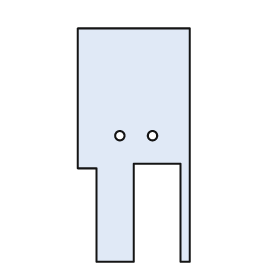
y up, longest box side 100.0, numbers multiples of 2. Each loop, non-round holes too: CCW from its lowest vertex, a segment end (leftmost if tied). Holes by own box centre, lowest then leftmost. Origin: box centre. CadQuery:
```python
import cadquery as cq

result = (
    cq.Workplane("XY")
    .moveTo(-16.0, -50.0)
    .lineTo(0.0, -50.0)
    .lineTo(0.0, -8.0)
    .lineTo(20.0, -8.0)
    .lineTo(20.0, -50.0)
    .lineTo(24.0, -50.0)
    .lineTo(24.0, 50.0)
    .lineTo(-24.0, 50.0)
    .lineTo(-24.0, -10.0)
    .lineTo(-16.0, -10.0)
    .close()
    .moveTo(-6.0, 4.0)
    .circle(2.0)
    .moveTo(8.0, 4.0)
    .circle(2.0)
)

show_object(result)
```